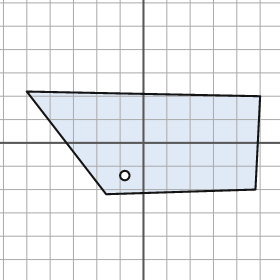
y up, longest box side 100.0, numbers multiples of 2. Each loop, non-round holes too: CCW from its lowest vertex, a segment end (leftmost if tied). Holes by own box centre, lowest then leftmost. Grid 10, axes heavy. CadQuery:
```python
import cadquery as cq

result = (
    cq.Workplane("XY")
    .moveTo(-16.0, -22.0)
    .lineTo(48.0, -20.0)
    .lineTo(50.0, 20.0)
    .lineTo(-50.0, 22.0)
    .close()
    .moveTo(-8.0, -14.0)
    .circle(2.0)
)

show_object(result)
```